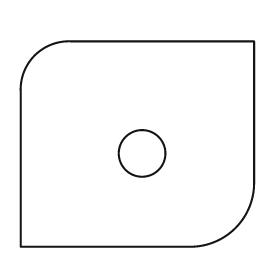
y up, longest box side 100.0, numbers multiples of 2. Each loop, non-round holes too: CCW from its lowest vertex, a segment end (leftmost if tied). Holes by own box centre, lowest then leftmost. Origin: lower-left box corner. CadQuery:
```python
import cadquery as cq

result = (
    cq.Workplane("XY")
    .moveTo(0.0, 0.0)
    .lineTo(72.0, 0.0)
    .threePointArc((92.0, 8.0), (100.0, 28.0))
    .lineTo(100.0, 88.0)
    .lineTo(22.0, 88.0)
    .threePointArc((6.0, 82.0), (0.0, 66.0))
    .close()
    .moveTo(52.0, 40.0)
    .circle(10.0)
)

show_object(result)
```